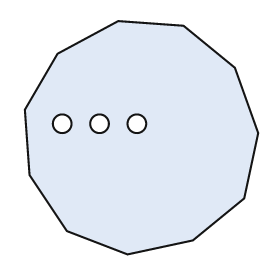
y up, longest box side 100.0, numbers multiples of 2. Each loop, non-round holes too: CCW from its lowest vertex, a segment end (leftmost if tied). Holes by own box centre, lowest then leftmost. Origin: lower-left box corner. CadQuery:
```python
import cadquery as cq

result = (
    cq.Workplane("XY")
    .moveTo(44.0, 0.0)
    .lineTo(72.0, 6.0)
    .lineTo(94.0, 24.0)
    .lineTo(100.0, 52.0)
    .lineTo(90.0, 80.0)
    .lineTo(68.0, 98.0)
    .lineTo(40.0, 100.0)
    .lineTo(14.0, 86.0)
    .lineTo(0.0, 62.0)
    .lineTo(2.0, 34.0)
    .lineTo(18.0, 10.0)
    .close()
    .moveTo(16.0, 56.0)
    .circle(4.0)
    .moveTo(32.0, 56.0)
    .circle(4.0)
    .moveTo(48.0, 56.0)
    .circle(4.0)
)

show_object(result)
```